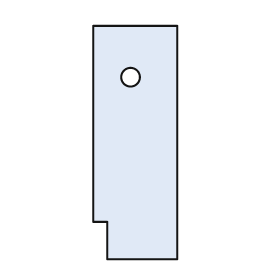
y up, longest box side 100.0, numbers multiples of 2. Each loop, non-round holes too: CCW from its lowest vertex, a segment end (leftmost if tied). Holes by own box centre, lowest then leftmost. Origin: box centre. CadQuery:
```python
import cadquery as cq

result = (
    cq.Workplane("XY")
    .moveTo(-12.0, -50.0)
    .lineTo(18.0, -50.0)
    .lineTo(18.0, 50.0)
    .lineTo(-18.0, 50.0)
    .lineTo(-18.0, -34.0)
    .lineTo(-12.0, -34.0)
    .close()
    .moveTo(-2.0, 28.0)
    .circle(4.0)
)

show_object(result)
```